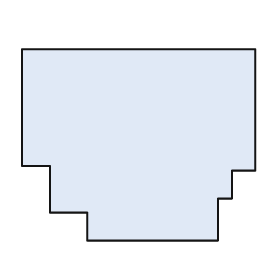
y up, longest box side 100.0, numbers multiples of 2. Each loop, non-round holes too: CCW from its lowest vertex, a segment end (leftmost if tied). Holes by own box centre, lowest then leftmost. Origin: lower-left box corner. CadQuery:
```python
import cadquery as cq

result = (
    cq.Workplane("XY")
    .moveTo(28.0, 0.0)
    .lineTo(84.0, 0.0)
    .lineTo(84.0, 18.0)
    .lineTo(90.0, 18.0)
    .lineTo(90.0, 30.0)
    .lineTo(100.0, 30.0)
    .lineTo(100.0, 82.0)
    .lineTo(0.0, 82.0)
    .lineTo(0.0, 32.0)
    .lineTo(12.0, 32.0)
    .lineTo(12.0, 12.0)
    .lineTo(28.0, 12.0)
    .close()
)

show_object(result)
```